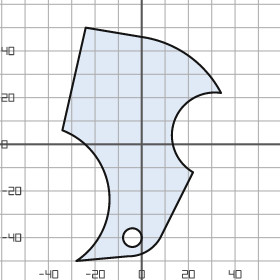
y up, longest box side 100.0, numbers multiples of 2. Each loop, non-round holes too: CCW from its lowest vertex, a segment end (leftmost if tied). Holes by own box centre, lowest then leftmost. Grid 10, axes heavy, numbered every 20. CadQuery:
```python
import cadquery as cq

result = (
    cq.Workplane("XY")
    .moveTo(-28.0, -50.0)
    .lineTo(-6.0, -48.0)
    .threePointArc((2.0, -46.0), (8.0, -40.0))
    .lineTo(22.0, -12.0)
    .threePointArc((14.0, 10.0), (34.0, 22.0))
    .threePointArc((20.0, 38.0), (0.0, 46.0))
    .lineTo(-24.0, 50.0)
    .lineTo(-34.0, 6.0)
    .threePointArc((-14.0, -20.0), (-28.0, -50.0))
    .close()
    .moveTo(-4.0, -40.0)
    .circle(4.0)
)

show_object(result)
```